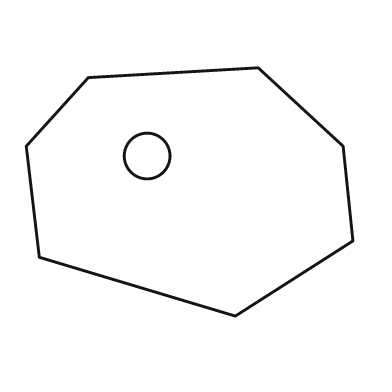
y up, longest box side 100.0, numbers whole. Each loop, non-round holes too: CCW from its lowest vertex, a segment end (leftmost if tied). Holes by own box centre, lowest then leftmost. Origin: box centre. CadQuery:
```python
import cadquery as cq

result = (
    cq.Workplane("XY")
    .moveTo(14.0, -38.0)
    .lineTo(50.0, -15.0)
    .lineTo(47.0, 14.0)
    .lineTo(21.0, 38.0)
    .lineTo(-31.0, 35.0)
    .lineTo(-50.0, 14.0)
    .lineTo(-46.0, -20.0)
    .close()
    .moveTo(-13.0, 11.0)
    .circle(7.0)
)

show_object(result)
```